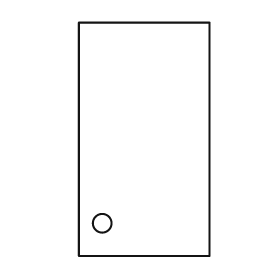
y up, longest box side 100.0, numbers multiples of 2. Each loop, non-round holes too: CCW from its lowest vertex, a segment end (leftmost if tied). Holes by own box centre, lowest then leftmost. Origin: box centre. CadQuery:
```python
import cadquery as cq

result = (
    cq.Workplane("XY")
    .moveTo(-28.0, -50.0)
    .lineTo(28.0, -50.0)
    .lineTo(28.0, 50.0)
    .lineTo(-28.0, 50.0)
    .close()
    .moveTo(-18.0, -36.0)
    .circle(4.0)
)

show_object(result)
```